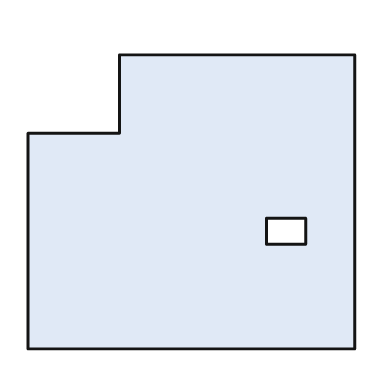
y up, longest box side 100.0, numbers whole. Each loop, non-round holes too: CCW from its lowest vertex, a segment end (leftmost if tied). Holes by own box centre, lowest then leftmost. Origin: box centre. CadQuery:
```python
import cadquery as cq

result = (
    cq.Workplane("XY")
    .moveTo(-50.0, -45.0)
    .lineTo(50.0, -45.0)
    .lineTo(50.0, 45.0)
    .lineTo(-22.0, 45.0)
    .lineTo(-22.0, 21.0)
    .lineTo(-50.0, 21.0)
    .close()
    .moveTo(23.0, -13.0)
    .lineTo(35.0, -13.0)
    .lineTo(35.0, -5.0)
    .lineTo(23.0, -5.0)
    .close()
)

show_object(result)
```